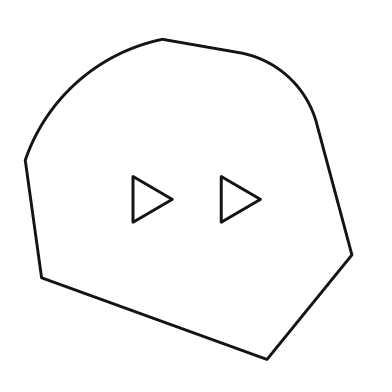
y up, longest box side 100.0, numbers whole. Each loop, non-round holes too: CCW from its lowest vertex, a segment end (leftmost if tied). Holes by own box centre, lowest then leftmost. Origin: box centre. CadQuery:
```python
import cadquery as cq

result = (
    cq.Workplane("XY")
    .moveTo(24.0, -49.0)
    .lineTo(50.0, -17.0)
    .lineTo(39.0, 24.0)
    .threePointArc((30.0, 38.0), (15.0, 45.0))
    .lineTo(-8.0, 49.0)
    .threePointArc((-34.0, 36.0), (-50.0, 12.0))
    .lineTo(-45.0, -24.0)
    .close()
    .moveTo(-17.0, -7.0)
    .lineTo(-5.0, 0.0)
    .lineTo(-17.0, 7.0)
    .close()
    .moveTo(10.0, -7.0)
    .lineTo(22.0, 0.0)
    .lineTo(10.0, 7.0)
    .close()
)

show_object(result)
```